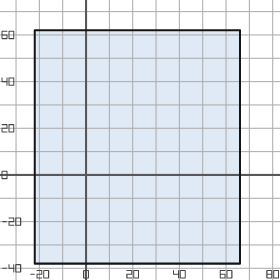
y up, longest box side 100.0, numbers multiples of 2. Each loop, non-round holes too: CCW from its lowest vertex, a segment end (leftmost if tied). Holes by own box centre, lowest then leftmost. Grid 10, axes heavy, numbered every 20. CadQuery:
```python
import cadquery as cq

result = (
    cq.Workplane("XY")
    .moveTo(-22.0, -38.0)
    .lineTo(66.0, -38.0)
    .lineTo(66.0, 62.0)
    .lineTo(-22.0, 62.0)
    .close()
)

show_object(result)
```